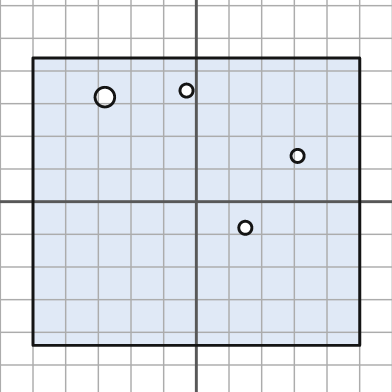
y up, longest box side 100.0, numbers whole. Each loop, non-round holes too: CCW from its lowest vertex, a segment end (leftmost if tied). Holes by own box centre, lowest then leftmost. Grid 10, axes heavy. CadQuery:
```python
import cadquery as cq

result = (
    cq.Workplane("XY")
    .moveTo(-50.0, -44.0)
    .lineTo(50.0, -44.0)
    .lineTo(50.0, 44.0)
    .lineTo(-50.0, 44.0)
    .close()
    .moveTo(15.0, -8.0)
    .circle(2.0)
    .moveTo(31.0, 14.0)
    .circle(2.0)
    .moveTo(-28.0, 32.0)
    .circle(3.0)
    .moveTo(-3.0, 34.0)
    .circle(2.0)
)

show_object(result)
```